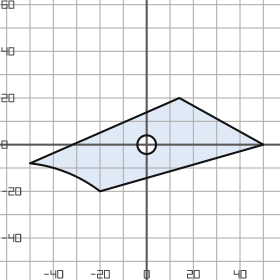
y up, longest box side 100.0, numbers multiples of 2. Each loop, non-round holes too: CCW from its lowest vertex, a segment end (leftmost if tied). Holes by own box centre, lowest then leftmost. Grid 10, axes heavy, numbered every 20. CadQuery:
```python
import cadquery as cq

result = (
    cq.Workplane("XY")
    .moveTo(-20.0, -20.0)
    .lineTo(50.0, 0.0)
    .lineTo(14.0, 20.0)
    .lineTo(-50.0, -8.0)
    .threePointArc((-34.0, -12.0), (-20.0, -20.0))
    .close()
    .moveTo(0.0, 0.0)
    .circle(4.0)
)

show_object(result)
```